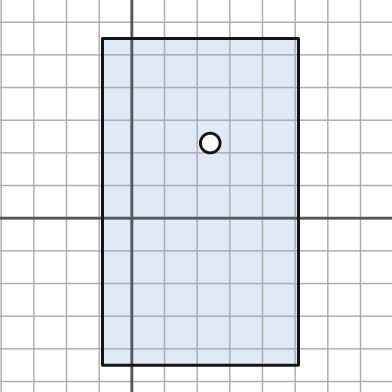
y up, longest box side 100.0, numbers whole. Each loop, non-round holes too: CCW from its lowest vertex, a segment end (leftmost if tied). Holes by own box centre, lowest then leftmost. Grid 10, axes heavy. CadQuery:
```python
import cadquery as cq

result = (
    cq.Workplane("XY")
    .moveTo(-9.0, -45.0)
    .lineTo(51.0, -45.0)
    .lineTo(51.0, 55.0)
    .lineTo(-9.0, 55.0)
    .close()
    .moveTo(24.0, 23.0)
    .circle(3.0)
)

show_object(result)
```